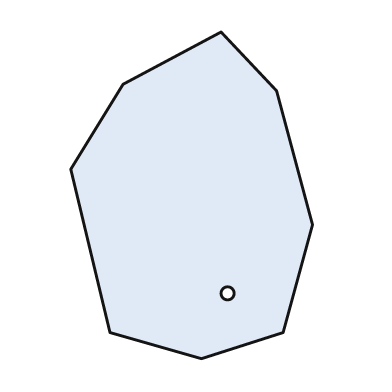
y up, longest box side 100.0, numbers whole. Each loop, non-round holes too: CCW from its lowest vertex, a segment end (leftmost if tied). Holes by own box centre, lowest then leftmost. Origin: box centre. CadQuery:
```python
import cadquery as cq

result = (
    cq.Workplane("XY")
    .moveTo(3.0, -50.0)
    .lineTo(28.0, -42.0)
    .lineTo(37.0, -9.0)
    .lineTo(26.0, 32.0)
    .lineTo(9.0, 50.0)
    .lineTo(-21.0, 34.0)
    .lineTo(-37.0, 8.0)
    .lineTo(-25.0, -42.0)
    .close()
    .moveTo(11.0, -30.0)
    .circle(2.0)
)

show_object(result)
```